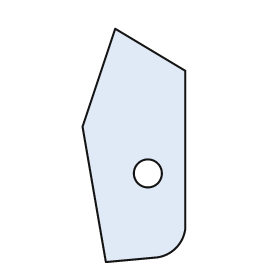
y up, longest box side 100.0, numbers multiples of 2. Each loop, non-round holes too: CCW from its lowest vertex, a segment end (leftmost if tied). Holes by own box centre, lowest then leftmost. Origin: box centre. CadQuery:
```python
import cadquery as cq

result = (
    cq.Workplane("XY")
    .moveTo(-12.0, -50.0)
    .lineTo(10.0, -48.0)
    .threePointArc((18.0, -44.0), (22.0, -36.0))
    .lineTo(22.0, 32.0)
    .lineTo(-8.0, 50.0)
    .lineTo(-22.0, 8.0)
    .close()
    .moveTo(6.0, -12.0)
    .circle(6.0)
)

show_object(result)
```